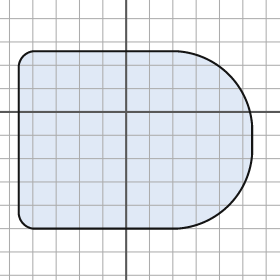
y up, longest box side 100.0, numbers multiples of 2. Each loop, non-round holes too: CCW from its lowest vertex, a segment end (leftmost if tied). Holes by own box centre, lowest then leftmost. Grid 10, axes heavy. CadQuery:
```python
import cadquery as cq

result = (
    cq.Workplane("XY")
    .moveTo(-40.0, -50.0)
    .lineTo(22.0, -50.0)
    .threePointArc((44.0, -40.0), (54.0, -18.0))
    .lineTo(54.0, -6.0)
    .threePointArc((44.0, 16.0), (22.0, 26.0))
    .lineTo(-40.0, 26.0)
    .threePointArc((-44.0, 24.0), (-46.0, 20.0))
    .lineTo(-46.0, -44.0)
    .threePointArc((-44.0, -48.0), (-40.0, -50.0))
    .close()
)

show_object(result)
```